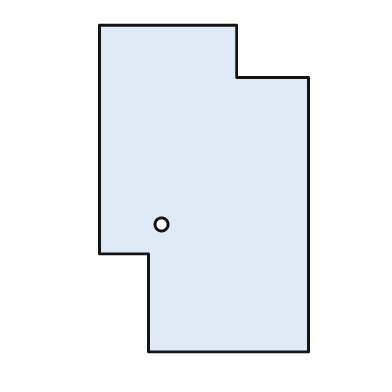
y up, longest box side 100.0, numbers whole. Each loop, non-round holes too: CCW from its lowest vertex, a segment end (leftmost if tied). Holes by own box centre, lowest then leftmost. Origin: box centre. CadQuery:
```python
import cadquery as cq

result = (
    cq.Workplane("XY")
    .moveTo(-17.0, -50.0)
    .lineTo(32.0, -50.0)
    .lineTo(32.0, 34.0)
    .lineTo(10.0, 34.0)
    .lineTo(10.0, 50.0)
    .lineTo(-32.0, 50.0)
    .lineTo(-32.0, -20.0)
    .lineTo(-17.0, -20.0)
    .close()
    .moveTo(-13.0, -11.0)
    .circle(2.0)
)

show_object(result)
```